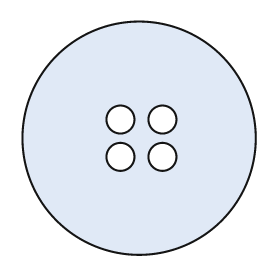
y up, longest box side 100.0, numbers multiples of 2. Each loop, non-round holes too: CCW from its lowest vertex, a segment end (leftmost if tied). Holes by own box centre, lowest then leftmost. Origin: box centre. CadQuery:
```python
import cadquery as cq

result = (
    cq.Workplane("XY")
    .moveTo(0.0, 0.0)
    .circle(50.0)
    .moveTo(-8.0, -8.0)
    .circle(6.0)
    .moveTo(10.0, -8.0)
    .circle(6.0)
    .moveTo(-8.0, 8.0)
    .circle(6.0)
    .moveTo(10.0, 8.0)
    .circle(6.0)
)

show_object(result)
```